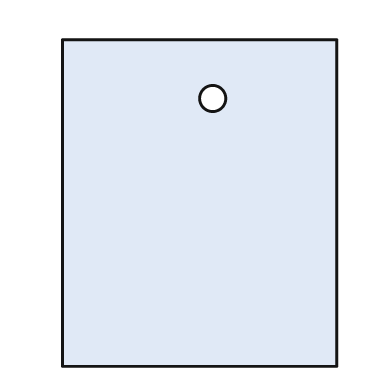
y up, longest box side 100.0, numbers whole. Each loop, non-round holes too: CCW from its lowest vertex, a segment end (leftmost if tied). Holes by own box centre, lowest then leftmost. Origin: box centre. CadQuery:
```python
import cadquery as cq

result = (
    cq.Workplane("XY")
    .moveTo(-42.0, -50.0)
    .lineTo(42.0, -50.0)
    .lineTo(42.0, 50.0)
    .lineTo(-42.0, 50.0)
    .close()
    .moveTo(4.0, 32.0)
    .circle(4.0)
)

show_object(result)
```